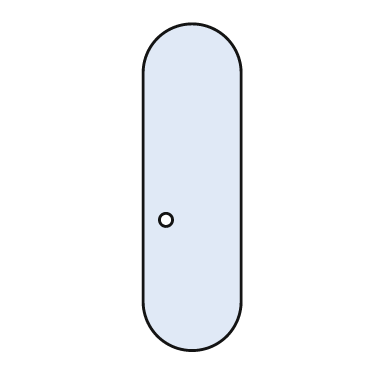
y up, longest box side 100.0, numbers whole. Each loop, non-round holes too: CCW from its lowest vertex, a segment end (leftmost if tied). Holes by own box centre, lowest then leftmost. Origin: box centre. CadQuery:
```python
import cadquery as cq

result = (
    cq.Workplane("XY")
    .moveTo(-15.0, -35.0)
    .threePointArc((0.0, -50.0), (15.0, -35.0))
    .lineTo(15.0, 35.0)
    .threePointArc((0.0, 50.0), (-15.0, 35.0))
    .close()
    .moveTo(-8.0, -10.0)
    .circle(2.0)
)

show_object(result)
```